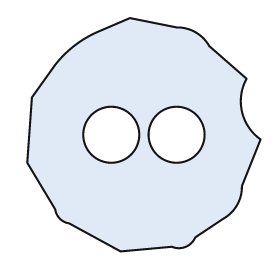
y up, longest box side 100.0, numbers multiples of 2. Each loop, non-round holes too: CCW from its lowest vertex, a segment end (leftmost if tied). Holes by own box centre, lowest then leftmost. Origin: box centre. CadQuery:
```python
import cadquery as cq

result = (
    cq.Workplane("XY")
    .moveTo(-10.0, -50.0)
    .lineTo(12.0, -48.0)
    .threePointArc((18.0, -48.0), (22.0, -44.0))
    .lineTo(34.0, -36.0)
    .threePointArc((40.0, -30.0), (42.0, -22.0))
    .lineTo(50.0, -2.0)
    .threePointArc((42.0, 10.0), (44.0, 24.0))
    .lineTo(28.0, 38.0)
    .threePointArc((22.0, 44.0), (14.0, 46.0))
    .lineTo(-6.0, 50.0)
    .lineTo(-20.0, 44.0)
    .threePointArc((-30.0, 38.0), (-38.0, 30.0))
    .lineTo(-48.0, 16.0)
    .lineTo(-50.0, -12.0)
    .lineTo(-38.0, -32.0)
    .threePointArc((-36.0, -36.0), (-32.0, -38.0))
    .close()
    .moveTo(-14.0, 0.0)
    .circle(12.0)
    .moveTo(14.0, 0.0)
    .circle(12.0)
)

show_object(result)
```